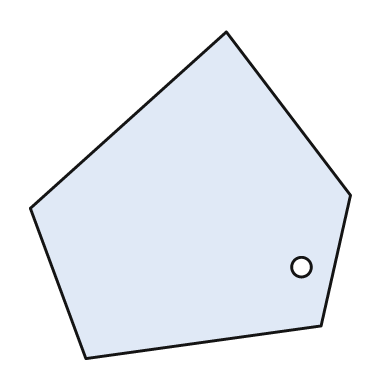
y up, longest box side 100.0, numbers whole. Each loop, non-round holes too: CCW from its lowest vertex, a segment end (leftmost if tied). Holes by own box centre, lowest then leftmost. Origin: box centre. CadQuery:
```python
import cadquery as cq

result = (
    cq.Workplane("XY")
    .moveTo(-32.0, -50.0)
    .lineTo(40.0, -40.0)
    .lineTo(49.0, 0.0)
    .lineTo(11.0, 50.0)
    .lineTo(-49.0, -4.0)
    .close()
    .moveTo(34.0, -22.0)
    .circle(3.0)
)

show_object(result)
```